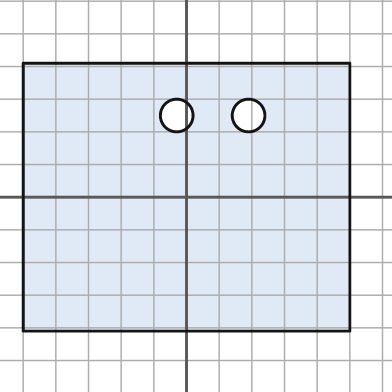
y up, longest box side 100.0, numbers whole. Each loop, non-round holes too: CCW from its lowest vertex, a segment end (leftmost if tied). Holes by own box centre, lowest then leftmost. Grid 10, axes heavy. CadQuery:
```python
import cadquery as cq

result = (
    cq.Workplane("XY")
    .moveTo(-50.0, -41.0)
    .lineTo(50.0, -41.0)
    .lineTo(50.0, 41.0)
    .lineTo(-50.0, 41.0)
    .close()
    .moveTo(-3.0, 25.0)
    .circle(5.0)
    .moveTo(19.0, 25.0)
    .circle(5.0)
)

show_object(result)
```